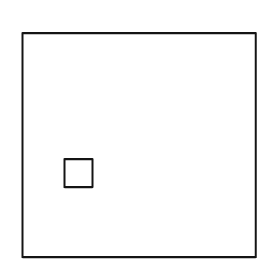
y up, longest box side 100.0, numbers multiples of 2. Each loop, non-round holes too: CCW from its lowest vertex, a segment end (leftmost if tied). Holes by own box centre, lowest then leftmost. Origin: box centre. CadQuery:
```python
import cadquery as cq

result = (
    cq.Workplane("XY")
    .moveTo(-50.0, -48.0)
    .lineTo(50.0, -48.0)
    .lineTo(50.0, 48.0)
    .lineTo(-50.0, 48.0)
    .close()
    .moveTo(-32.0, -18.0)
    .lineTo(-20.0, -18.0)
    .lineTo(-20.0, -6.0)
    .lineTo(-32.0, -6.0)
    .close()
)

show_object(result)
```